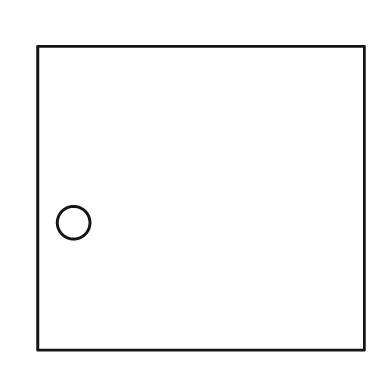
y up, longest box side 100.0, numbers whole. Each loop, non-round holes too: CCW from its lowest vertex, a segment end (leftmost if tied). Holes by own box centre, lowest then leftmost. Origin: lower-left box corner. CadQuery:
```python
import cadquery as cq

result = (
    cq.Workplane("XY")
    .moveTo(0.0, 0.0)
    .lineTo(100.0, 0.0)
    .lineTo(100.0, 93.0)
    .lineTo(0.0, 93.0)
    .close()
    .moveTo(11.0, 39.0)
    .circle(5.0)
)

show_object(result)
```